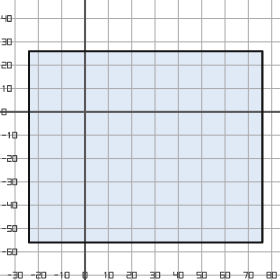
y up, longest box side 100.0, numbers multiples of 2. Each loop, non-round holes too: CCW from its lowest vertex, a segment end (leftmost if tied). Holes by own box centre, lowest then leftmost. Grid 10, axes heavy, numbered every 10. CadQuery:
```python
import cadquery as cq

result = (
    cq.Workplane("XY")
    .moveTo(-24.0, -56.0)
    .lineTo(76.0, -56.0)
    .lineTo(76.0, 26.0)
    .lineTo(-24.0, 26.0)
    .close()
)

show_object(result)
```